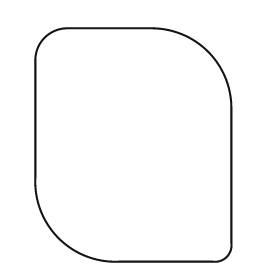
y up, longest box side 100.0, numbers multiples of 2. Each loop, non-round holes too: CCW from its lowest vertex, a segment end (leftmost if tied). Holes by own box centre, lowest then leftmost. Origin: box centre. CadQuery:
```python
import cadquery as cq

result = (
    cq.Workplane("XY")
    .moveTo(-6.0, -50.0)
    .lineTo(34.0, -50.0)
    .threePointArc((40.0, -48.0), (42.0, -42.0))
    .lineTo(42.0, 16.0)
    .threePointArc((32.0, 40.0), (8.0, 50.0))
    .lineTo(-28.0, 50.0)
    .threePointArc((-38.0, 46.0), (-42.0, 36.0))
    .lineTo(-42.0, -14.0)
    .threePointArc((-32.0, -40.0), (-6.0, -50.0))
    .close()
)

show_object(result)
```